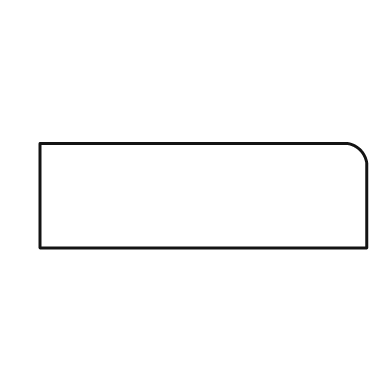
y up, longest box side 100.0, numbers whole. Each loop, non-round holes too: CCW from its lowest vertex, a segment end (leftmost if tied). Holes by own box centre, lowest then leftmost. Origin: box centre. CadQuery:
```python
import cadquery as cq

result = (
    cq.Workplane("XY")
    .moveTo(-50.0, -16.0)
    .lineTo(50.0, -16.0)
    .lineTo(50.0, 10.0)
    .threePointArc((48.0, 14.0), (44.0, 16.0))
    .lineTo(-50.0, 16.0)
    .close()
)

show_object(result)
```